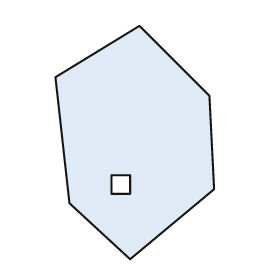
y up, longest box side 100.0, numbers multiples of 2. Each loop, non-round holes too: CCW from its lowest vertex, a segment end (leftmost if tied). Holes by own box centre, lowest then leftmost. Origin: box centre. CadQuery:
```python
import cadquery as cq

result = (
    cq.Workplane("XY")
    .moveTo(-2.0, -50.0)
    .lineTo(34.0, -20.0)
    .lineTo(32.0, 20.0)
    .lineTo(2.0, 50.0)
    .lineTo(-34.0, 28.0)
    .lineTo(-28.0, -26.0)
    .close()
    .moveTo(-10.0, -22.0)
    .lineTo(-2.0, -22.0)
    .lineTo(-2.0, -14.0)
    .lineTo(-10.0, -14.0)
    .close()
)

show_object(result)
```